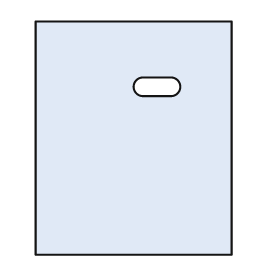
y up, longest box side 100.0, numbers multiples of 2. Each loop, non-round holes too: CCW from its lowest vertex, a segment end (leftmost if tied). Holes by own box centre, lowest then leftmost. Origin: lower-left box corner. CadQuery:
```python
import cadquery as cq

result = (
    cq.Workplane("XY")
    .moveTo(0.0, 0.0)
    .lineTo(84.0, 0.0)
    .lineTo(84.0, 100.0)
    .lineTo(0.0, 100.0)
    .close()
    .moveTo(46.0, 68.0)
    .lineTo(58.0, 68.0)
    .threePointArc((62.0, 72.0), (58.0, 76.0))
    .lineTo(46.0, 76.0)
    .threePointArc((42.0, 72.0), (46.0, 68.0))
    .close()
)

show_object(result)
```